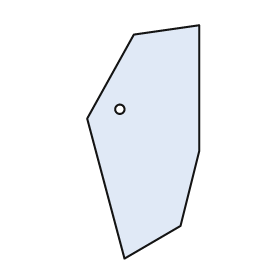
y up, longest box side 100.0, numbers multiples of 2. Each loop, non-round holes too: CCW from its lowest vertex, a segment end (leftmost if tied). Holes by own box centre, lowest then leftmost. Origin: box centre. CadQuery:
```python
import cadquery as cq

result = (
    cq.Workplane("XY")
    .moveTo(-8.0, -50.0)
    .lineTo(16.0, -36.0)
    .lineTo(24.0, -4.0)
    .lineTo(24.0, 50.0)
    .lineTo(-4.0, 46.0)
    .lineTo(-24.0, 10.0)
    .close()
    .moveTo(-10.0, 14.0)
    .circle(2.0)
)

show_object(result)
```